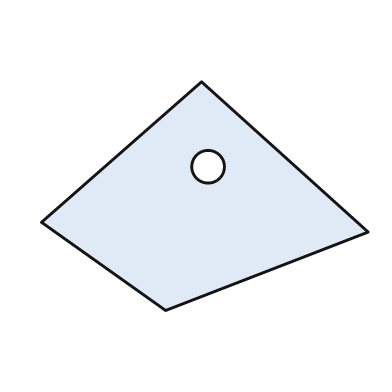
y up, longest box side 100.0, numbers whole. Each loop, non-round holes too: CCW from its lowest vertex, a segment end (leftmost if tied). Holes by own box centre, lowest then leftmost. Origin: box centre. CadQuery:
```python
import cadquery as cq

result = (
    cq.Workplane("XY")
    .moveTo(-12.0, -35.0)
    .lineTo(50.0, -11.0)
    .lineTo(-1.0, 35.0)
    .lineTo(-50.0, -8.0)
    .close()
    .moveTo(1.0, 9.0)
    .circle(5.0)
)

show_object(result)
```